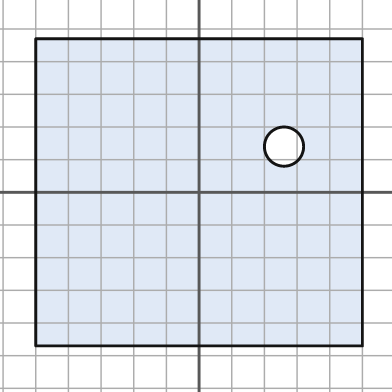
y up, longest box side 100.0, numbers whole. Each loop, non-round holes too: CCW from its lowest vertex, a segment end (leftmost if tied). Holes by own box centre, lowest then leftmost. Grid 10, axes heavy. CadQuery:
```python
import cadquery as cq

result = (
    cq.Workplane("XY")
    .moveTo(-50.0, -47.0)
    .lineTo(50.0, -47.0)
    .lineTo(50.0, 47.0)
    .lineTo(-50.0, 47.0)
    .close()
    .moveTo(26.0, 14.0)
    .circle(6.0)
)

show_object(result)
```